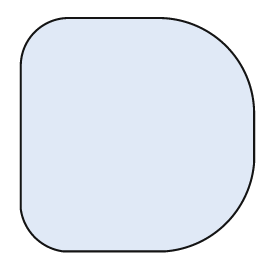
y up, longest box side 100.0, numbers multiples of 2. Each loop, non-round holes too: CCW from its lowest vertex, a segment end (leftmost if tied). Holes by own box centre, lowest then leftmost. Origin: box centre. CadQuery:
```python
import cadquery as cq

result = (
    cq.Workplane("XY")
    .moveTo(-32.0, -50.0)
    .lineTo(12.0, -50.0)
    .threePointArc((38.0, -38.0), (50.0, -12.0))
    .lineTo(50.0, 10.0)
    .threePointArc((38.0, 38.0), (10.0, 50.0))
    .lineTo(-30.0, 50.0)
    .threePointArc((-44.0, 44.0), (-50.0, 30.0))
    .lineTo(-50.0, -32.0)
    .threePointArc((-44.0, -44.0), (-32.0, -50.0))
    .close()
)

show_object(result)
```